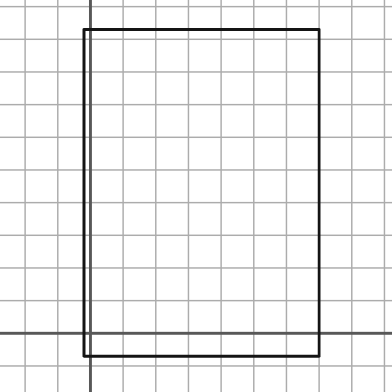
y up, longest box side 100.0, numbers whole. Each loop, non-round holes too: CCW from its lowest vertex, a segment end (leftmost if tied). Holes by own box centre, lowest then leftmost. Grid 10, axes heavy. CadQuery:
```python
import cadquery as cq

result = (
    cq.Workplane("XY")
    .moveTo(-2.0, -7.0)
    .lineTo(70.0, -7.0)
    .lineTo(70.0, 93.0)
    .lineTo(-2.0, 93.0)
    .close()
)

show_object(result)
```